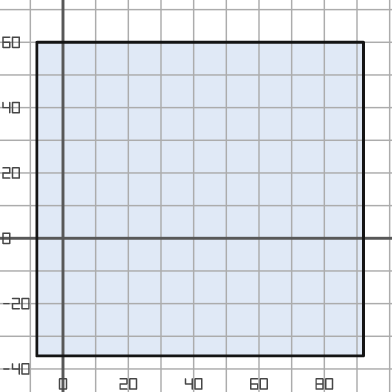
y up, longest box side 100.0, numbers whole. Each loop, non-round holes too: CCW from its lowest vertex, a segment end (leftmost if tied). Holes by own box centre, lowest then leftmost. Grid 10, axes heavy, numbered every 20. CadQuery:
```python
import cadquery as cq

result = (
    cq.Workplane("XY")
    .moveTo(-8.0, -36.0)
    .lineTo(92.0, -36.0)
    .lineTo(92.0, 60.0)
    .lineTo(-8.0, 60.0)
    .close()
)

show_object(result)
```